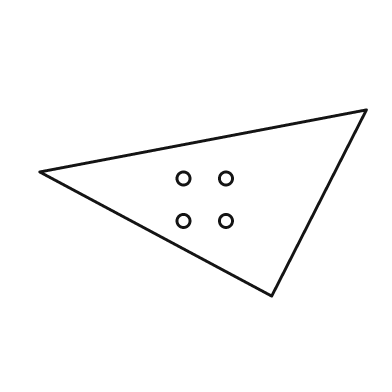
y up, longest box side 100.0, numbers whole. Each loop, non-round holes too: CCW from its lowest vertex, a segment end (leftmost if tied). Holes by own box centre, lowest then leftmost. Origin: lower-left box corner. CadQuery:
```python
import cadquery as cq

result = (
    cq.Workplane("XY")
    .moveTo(71.0, 0.0)
    .lineTo(100.0, 57.0)
    .lineTo(0.0, 38.0)
    .close()
    .moveTo(44.0, 23.0)
    .circle(2.0)
    .moveTo(57.0, 23.0)
    .circle(2.0)
    .moveTo(44.0, 36.0)
    .circle(2.0)
    .moveTo(57.0, 36.0)
    .circle(2.0)
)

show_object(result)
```